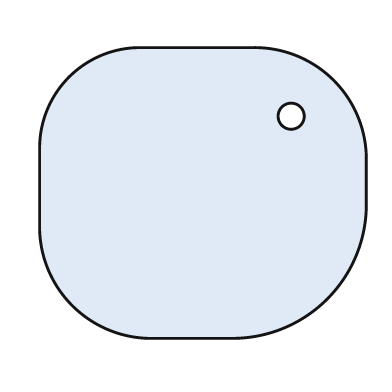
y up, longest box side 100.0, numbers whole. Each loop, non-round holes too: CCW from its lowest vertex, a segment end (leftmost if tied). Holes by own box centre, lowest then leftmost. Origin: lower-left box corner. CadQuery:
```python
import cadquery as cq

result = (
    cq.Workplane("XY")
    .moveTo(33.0, 0.0)
    .lineTo(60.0, 0.0)
    .threePointArc((88.0, 12.0), (100.0, 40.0))
    .lineTo(100.0, 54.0)
    .threePointArc((90.0, 79.0), (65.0, 89.0))
    .lineTo(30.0, 89.0)
    .threePointArc((9.0, 80.0), (0.0, 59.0))
    .lineTo(0.0, 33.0)
    .threePointArc((10.0, 10.0), (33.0, 0.0))
    .close()
    .moveTo(77.0, 68.0)
    .circle(4.0)
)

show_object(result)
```